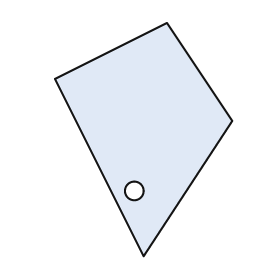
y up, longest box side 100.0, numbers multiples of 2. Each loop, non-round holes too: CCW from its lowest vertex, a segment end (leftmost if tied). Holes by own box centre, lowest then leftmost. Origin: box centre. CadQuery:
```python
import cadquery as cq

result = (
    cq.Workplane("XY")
    .moveTo(0.0, -50.0)
    .lineTo(38.0, 8.0)
    .lineTo(10.0, 50.0)
    .lineTo(-38.0, 26.0)
    .close()
    .moveTo(-4.0, -22.0)
    .circle(4.0)
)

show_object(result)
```